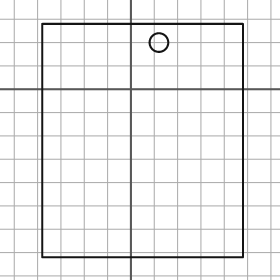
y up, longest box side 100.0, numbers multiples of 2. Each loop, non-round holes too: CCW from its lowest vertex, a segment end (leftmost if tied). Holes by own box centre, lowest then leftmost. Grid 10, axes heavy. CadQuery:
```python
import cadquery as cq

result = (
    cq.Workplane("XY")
    .moveTo(-38.0, -72.0)
    .lineTo(48.0, -72.0)
    .lineTo(48.0, 28.0)
    .lineTo(-38.0, 28.0)
    .close()
    .moveTo(12.0, 20.0)
    .circle(4.0)
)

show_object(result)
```